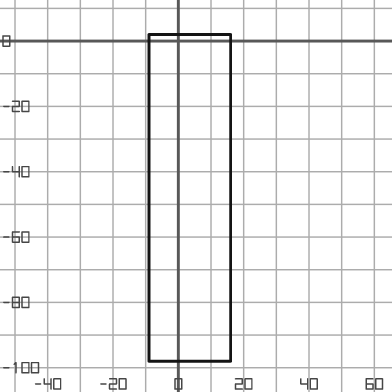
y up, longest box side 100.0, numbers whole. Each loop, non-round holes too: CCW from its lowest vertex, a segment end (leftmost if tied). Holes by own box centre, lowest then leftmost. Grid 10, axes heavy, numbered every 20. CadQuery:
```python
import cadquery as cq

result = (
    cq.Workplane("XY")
    .moveTo(-9.0, -98.0)
    .lineTo(16.0, -98.0)
    .lineTo(16.0, 2.0)
    .lineTo(-9.0, 2.0)
    .close()
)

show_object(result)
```